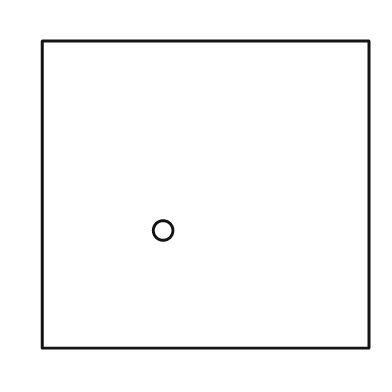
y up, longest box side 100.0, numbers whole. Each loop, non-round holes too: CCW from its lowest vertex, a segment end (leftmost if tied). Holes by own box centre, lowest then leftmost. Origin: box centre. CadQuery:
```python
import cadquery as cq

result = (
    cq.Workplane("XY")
    .moveTo(-50.0, -47.0)
    .lineTo(50.0, -47.0)
    .lineTo(50.0, 47.0)
    .lineTo(-50.0, 47.0)
    .close()
    .moveTo(-13.0, -11.0)
    .circle(3.0)
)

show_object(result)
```